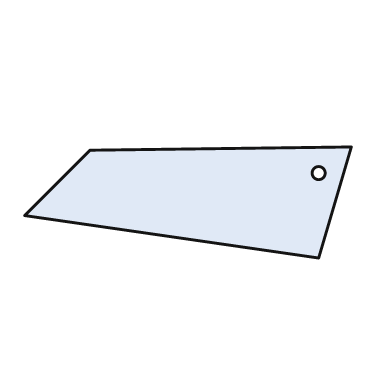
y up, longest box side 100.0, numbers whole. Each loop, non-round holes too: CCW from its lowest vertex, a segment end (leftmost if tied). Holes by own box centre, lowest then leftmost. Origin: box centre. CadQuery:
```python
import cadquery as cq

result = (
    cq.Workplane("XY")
    .moveTo(40.0, -17.0)
    .lineTo(50.0, 17.0)
    .lineTo(-30.0, 16.0)
    .lineTo(-50.0, -4.0)
    .close()
    .moveTo(40.0, 9.0)
    .circle(2.0)
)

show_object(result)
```